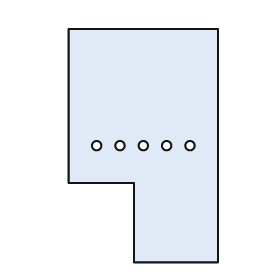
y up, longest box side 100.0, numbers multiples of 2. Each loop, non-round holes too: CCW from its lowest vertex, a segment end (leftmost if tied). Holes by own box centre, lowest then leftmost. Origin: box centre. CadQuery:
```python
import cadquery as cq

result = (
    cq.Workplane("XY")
    .moveTo(-4.0, -50.0)
    .lineTo(32.0, -50.0)
    .lineTo(32.0, 50.0)
    .lineTo(-32.0, 50.0)
    .lineTo(-32.0, -16.0)
    .lineTo(-4.0, -16.0)
    .close()
    .moveTo(-20.0, 0.0)
    .circle(2.0)
    .moveTo(-10.0, 0.0)
    .circle(2.0)
    .moveTo(0.0, 0.0)
    .circle(2.0)
    .moveTo(10.0, 0.0)
    .circle(2.0)
    .moveTo(20.0, 0.0)
    .circle(2.0)
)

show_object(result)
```